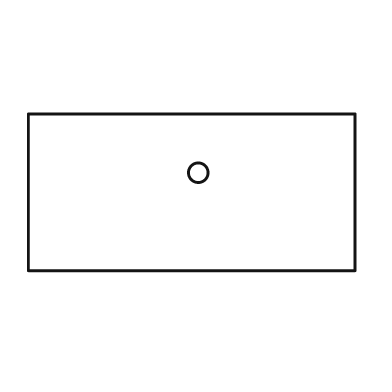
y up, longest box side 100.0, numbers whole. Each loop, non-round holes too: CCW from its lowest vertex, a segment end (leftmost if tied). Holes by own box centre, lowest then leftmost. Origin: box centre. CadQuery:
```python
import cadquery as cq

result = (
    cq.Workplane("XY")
    .moveTo(-50.0, -24.0)
    .lineTo(50.0, -24.0)
    .lineTo(50.0, 24.0)
    .lineTo(-50.0, 24.0)
    .close()
    .moveTo(2.0, 6.0)
    .circle(3.0)
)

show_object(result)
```